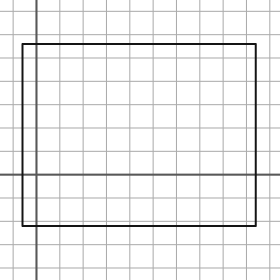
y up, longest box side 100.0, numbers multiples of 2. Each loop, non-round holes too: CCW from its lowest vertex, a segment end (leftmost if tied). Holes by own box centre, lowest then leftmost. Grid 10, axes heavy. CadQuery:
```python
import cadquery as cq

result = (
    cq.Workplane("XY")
    .moveTo(-6.0, -22.0)
    .lineTo(94.0, -22.0)
    .lineTo(94.0, 56.0)
    .lineTo(-6.0, 56.0)
    .close()
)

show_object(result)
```